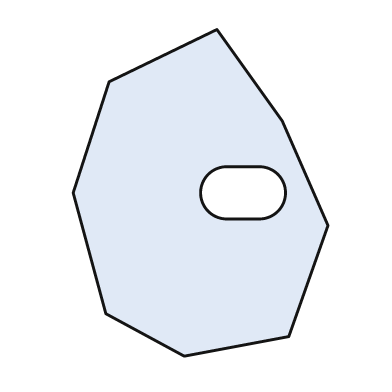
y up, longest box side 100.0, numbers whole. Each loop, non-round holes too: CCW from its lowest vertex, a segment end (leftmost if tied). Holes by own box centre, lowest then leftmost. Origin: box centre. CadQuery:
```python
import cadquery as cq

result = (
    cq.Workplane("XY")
    .moveTo(-5.0, -50.0)
    .lineTo(27.0, -44.0)
    .lineTo(39.0, -10.0)
    .lineTo(25.0, 22.0)
    .lineTo(5.0, 50.0)
    .lineTo(-28.0, 34.0)
    .lineTo(-39.0, 0.0)
    .lineTo(-29.0, -37.0)
    .close()
    .moveTo(8.0, -8.0)
    .lineTo(18.0, -8.0)
    .threePointArc((26.0, 0.0), (18.0, 8.0))
    .lineTo(8.0, 8.0)
    .threePointArc((0.0, 0.0), (8.0, -8.0))
    .close()
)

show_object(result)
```